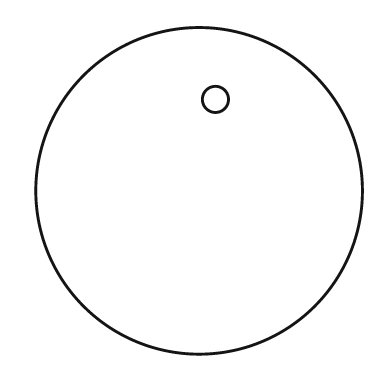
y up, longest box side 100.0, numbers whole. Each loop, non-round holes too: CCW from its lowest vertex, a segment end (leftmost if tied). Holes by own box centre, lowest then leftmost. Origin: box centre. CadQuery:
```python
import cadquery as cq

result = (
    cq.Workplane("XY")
    .moveTo(0.0, 0.0)
    .circle(50.0)
    .moveTo(5.0, 28.0)
    .circle(4.0)
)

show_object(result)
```